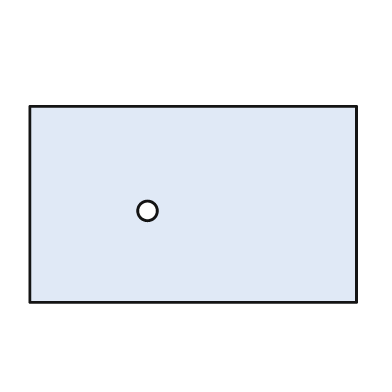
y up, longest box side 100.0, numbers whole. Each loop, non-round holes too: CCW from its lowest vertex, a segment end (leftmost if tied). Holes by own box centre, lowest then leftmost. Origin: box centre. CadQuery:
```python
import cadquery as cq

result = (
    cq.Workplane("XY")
    .moveTo(-50.0, -30.0)
    .lineTo(50.0, -30.0)
    .lineTo(50.0, 30.0)
    .lineTo(-50.0, 30.0)
    .close()
    .moveTo(-14.0, -2.0)
    .circle(3.0)
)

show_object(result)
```